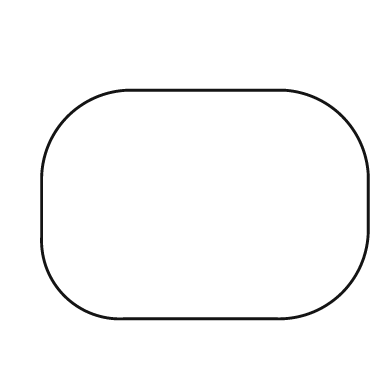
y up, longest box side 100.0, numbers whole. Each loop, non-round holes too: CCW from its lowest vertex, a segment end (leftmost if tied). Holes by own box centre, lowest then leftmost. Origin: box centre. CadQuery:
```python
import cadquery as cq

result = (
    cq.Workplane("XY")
    .moveTo(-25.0, -35.0)
    .lineTo(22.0, -35.0)
    .threePointArc((42.0, -27.0), (50.0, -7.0))
    .lineTo(50.0, 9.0)
    .threePointArc((42.0, 27.0), (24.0, 35.0))
    .lineTo(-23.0, 35.0)
    .threePointArc((-42.0, 27.0), (-50.0, 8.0))
    .lineTo(-50.0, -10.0)
    .threePointArc((-43.0, -28.0), (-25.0, -35.0))
    .close()
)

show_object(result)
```